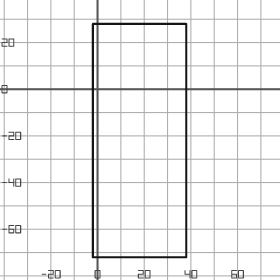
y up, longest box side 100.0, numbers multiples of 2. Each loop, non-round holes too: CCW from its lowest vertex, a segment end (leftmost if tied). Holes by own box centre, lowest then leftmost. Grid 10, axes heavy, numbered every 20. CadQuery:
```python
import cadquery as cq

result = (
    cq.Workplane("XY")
    .moveTo(-2.0, -72.0)
    .lineTo(38.0, -72.0)
    .lineTo(38.0, 28.0)
    .lineTo(-2.0, 28.0)
    .close()
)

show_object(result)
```